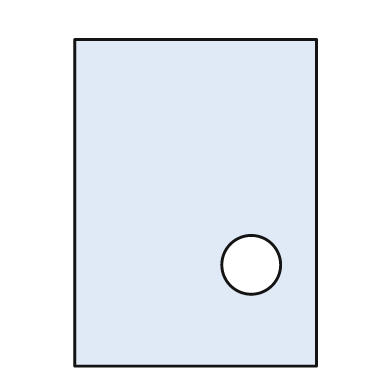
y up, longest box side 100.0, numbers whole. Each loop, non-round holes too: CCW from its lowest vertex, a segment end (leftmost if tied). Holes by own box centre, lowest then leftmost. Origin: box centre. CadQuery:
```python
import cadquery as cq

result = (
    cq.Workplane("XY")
    .moveTo(-37.0, -50.0)
    .lineTo(37.0, -50.0)
    .lineTo(37.0, 50.0)
    .lineTo(-37.0, 50.0)
    .close()
    .moveTo(17.0, -19.0)
    .circle(9.0)
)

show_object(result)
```